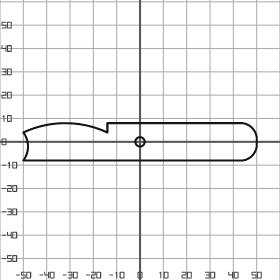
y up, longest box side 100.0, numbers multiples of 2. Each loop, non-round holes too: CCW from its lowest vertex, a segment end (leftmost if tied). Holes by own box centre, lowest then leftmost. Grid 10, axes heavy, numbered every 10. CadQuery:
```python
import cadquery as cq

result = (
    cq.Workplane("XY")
    .moveTo(-50.0, -8.0)
    .lineTo(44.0, -8.0)
    .threePointArc((48.0, -6.0), (50.0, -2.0))
    .lineTo(50.0, 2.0)
    .threePointArc((48.0, 6.0), (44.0, 8.0))
    .lineTo(-14.0, 8.0)
    .lineTo(-14.0, 4.0)
    .threePointArc((-32.0, 8.0), (-50.0, 4.0))
    .threePointArc((-48.0, -2.0), (-50.0, -8.0))
    .close()
    .moveTo(0.0, 0.0)
    .circle(2.0)
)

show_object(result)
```